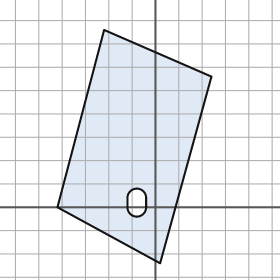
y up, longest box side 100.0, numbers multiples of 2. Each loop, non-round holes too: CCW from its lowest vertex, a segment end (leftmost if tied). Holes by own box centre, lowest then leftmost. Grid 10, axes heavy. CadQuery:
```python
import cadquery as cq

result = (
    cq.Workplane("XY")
    .moveTo(2.0, -24.0)
    .lineTo(24.0, 56.0)
    .lineTo(-22.0, 76.0)
    .lineTo(-42.0, 0.0)
    .close()
    .moveTo(-12.0, 0.0)
    .threePointArc((-8.0, -4.0), (-4.0, 0.0))
    .lineTo(-4.0, 4.0)
    .threePointArc((-8.0, 8.0), (-12.0, 4.0))
    .close()
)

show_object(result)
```